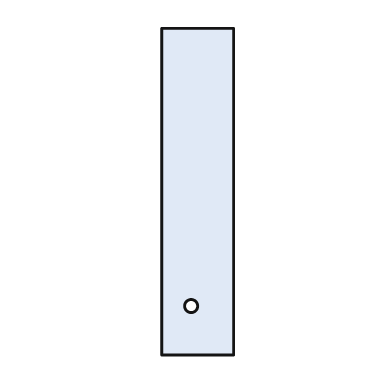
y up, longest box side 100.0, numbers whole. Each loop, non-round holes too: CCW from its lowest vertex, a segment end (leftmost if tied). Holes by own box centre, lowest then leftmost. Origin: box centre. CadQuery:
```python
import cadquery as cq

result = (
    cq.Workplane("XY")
    .moveTo(-11.0, -50.0)
    .lineTo(11.0, -50.0)
    .lineTo(11.0, 50.0)
    .lineTo(-11.0, 50.0)
    .close()
    .moveTo(-2.0, -35.0)
    .circle(2.0)
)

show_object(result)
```